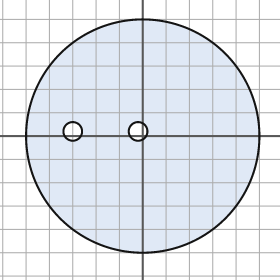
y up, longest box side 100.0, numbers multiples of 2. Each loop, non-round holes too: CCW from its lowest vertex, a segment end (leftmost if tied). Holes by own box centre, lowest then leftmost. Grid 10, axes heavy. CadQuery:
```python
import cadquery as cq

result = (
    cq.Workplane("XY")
    .moveTo(0.0, 0.0)
    .circle(50.0)
    .moveTo(-30.0, 2.0)
    .circle(4.0)
    .moveTo(-2.0, 2.0)
    .circle(4.0)
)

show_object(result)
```